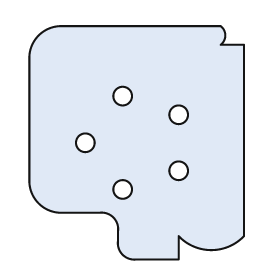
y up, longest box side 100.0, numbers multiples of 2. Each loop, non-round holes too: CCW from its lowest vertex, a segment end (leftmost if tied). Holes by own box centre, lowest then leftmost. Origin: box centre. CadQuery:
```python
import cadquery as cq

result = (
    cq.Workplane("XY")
    .moveTo(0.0, -50.0)
    .lineTo(18.0, -50.0)
    .lineTo(18.0, -40.0)
    .threePointArc((32.0, -46.0), (46.0, -40.0))
    .lineTo(46.0, 42.0)
    .lineTo(36.0, 42.0)
    .threePointArc((38.0, 46.0), (36.0, 50.0))
    .lineTo(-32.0, 50.0)
    .threePointArc((-42.0, 46.0), (-46.0, 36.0))
    .lineTo(-46.0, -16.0)
    .threePointArc((-42.0, -26.0), (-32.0, -30.0))
    .lineTo(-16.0, -30.0)
    .threePointArc((-10.0, -32.0), (-8.0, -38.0))
    .lineTo(-8.0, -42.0)
    .threePointArc((-6.0, -48.0), (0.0, -50.0))
    .close()
    .moveTo(-6.0, -20.0)
    .circle(4.0)
    .moveTo(18.0, -12.0)
    .circle(4.0)
    .moveTo(-22.0, 0.0)
    .circle(4.0)
    .moveTo(18.0, 12.0)
    .circle(4.0)
    .moveTo(-6.0, 20.0)
    .circle(4.0)
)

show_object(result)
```